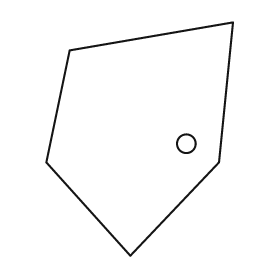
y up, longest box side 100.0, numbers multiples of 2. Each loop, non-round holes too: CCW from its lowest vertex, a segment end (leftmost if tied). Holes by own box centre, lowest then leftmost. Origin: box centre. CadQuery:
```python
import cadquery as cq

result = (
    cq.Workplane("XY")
    .moveTo(-4.0, -50.0)
    .lineTo(34.0, -10.0)
    .lineTo(40.0, 50.0)
    .lineTo(-30.0, 38.0)
    .lineTo(-40.0, -10.0)
    .close()
    .moveTo(20.0, -2.0)
    .circle(4.0)
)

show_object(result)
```